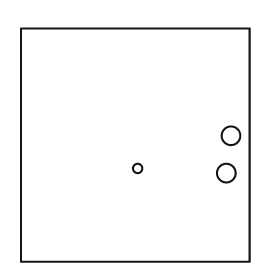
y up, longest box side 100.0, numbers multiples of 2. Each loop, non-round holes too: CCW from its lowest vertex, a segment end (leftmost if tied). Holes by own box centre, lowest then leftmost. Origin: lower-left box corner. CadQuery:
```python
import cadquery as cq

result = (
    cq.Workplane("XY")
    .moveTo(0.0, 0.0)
    .lineTo(98.0, 0.0)
    .lineTo(98.0, 100.0)
    .lineTo(0.0, 100.0)
    .close()
    .moveTo(88.0, 38.0)
    .circle(4.0)
    .moveTo(50.0, 40.0)
    .circle(2.0)
    .moveTo(90.0, 54.0)
    .circle(4.0)
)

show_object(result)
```